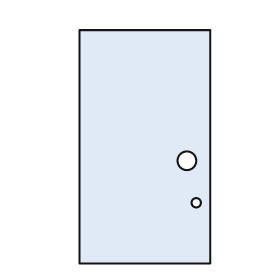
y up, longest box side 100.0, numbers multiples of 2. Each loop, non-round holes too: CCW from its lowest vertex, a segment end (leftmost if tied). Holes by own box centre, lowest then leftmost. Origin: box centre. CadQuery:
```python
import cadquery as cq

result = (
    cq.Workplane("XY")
    .moveTo(-28.0, -50.0)
    .lineTo(28.0, -50.0)
    .lineTo(28.0, 50.0)
    .lineTo(-28.0, 50.0)
    .close()
    .moveTo(22.0, -24.0)
    .circle(2.0)
    .moveTo(18.0, -6.0)
    .circle(4.0)
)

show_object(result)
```